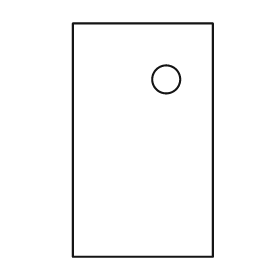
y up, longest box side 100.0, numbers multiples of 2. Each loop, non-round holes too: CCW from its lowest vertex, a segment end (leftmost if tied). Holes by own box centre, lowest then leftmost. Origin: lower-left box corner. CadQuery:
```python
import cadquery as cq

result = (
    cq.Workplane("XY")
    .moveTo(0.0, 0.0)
    .lineTo(60.0, 0.0)
    .lineTo(60.0, 100.0)
    .lineTo(0.0, 100.0)
    .close()
    .moveTo(40.0, 76.0)
    .circle(6.0)
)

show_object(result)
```